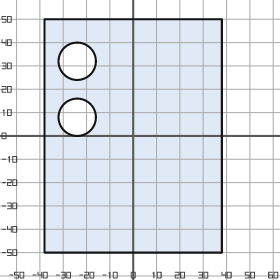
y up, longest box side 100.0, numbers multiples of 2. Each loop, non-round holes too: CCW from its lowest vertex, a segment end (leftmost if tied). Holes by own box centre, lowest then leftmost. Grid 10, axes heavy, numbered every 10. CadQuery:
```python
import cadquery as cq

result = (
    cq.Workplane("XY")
    .moveTo(-38.0, -50.0)
    .lineTo(38.0, -50.0)
    .lineTo(38.0, 50.0)
    .lineTo(-38.0, 50.0)
    .close()
    .moveTo(-24.0, 8.0)
    .circle(8.0)
    .moveTo(-24.0, 32.0)
    .circle(8.0)
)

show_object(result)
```